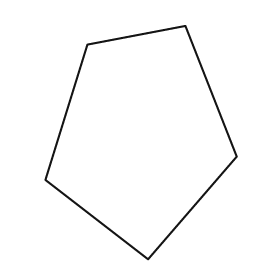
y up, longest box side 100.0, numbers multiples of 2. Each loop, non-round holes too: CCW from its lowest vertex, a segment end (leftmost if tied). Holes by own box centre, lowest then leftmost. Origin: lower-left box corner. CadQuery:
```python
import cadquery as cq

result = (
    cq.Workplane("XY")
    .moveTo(44.0, 0.0)
    .lineTo(82.0, 44.0)
    .lineTo(60.0, 100.0)
    .lineTo(18.0, 92.0)
    .lineTo(0.0, 34.0)
    .close()
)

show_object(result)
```